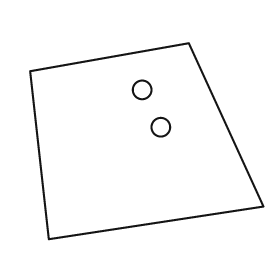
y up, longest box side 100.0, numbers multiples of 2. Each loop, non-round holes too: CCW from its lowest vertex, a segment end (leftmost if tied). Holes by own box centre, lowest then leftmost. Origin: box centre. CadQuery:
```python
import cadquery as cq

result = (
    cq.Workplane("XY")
    .moveTo(-42.0, -42.0)
    .lineTo(50.0, -28.0)
    .lineTo(18.0, 42.0)
    .lineTo(-50.0, 30.0)
    .close()
    .moveTo(6.0, 6.0)
    .circle(4.0)
    .moveTo(-2.0, 22.0)
    .circle(4.0)
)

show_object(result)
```